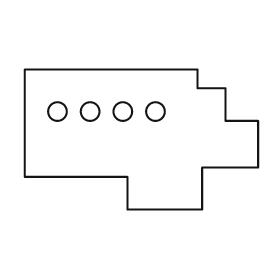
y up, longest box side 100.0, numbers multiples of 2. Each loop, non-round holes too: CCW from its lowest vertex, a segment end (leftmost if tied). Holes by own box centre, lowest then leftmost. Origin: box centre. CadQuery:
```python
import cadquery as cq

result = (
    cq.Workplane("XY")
    .moveTo(-6.0, -30.0)
    .lineTo(26.0, -30.0)
    .lineTo(26.0, -12.0)
    .lineTo(50.0, -12.0)
    .lineTo(50.0, 8.0)
    .lineTo(36.0, 8.0)
    .lineTo(36.0, 22.0)
    .lineTo(24.0, 22.0)
    .lineTo(24.0, 30.0)
    .lineTo(-50.0, 30.0)
    .lineTo(-50.0, -16.0)
    .lineTo(-6.0, -16.0)
    .close()
    .moveTo(-36.0, 12.0)
    .circle(4.0)
    .moveTo(-22.0, 12.0)
    .circle(4.0)
    .moveTo(-8.0, 12.0)
    .circle(4.0)
    .moveTo(6.0, 12.0)
    .circle(4.0)
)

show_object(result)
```